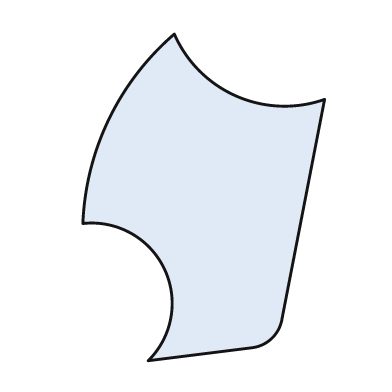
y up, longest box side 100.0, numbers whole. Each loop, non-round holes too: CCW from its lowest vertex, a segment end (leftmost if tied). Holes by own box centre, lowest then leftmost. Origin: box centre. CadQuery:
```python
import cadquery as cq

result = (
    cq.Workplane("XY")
    .moveTo(-17.0, -50.0)
    .lineTo(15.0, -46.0)
    .threePointArc((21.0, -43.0), (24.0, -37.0))
    .lineTo(37.0, 30.0)
    .threePointArc((10.0, 31.0), (-9.0, 50.0))
    .threePointArc((-29.0, 24.0), (-37.0, -8.0))
    .threePointArc((-12.0, -22.0), (-17.0, -50.0))
    .close()
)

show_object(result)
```